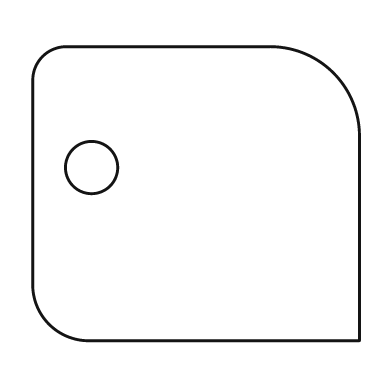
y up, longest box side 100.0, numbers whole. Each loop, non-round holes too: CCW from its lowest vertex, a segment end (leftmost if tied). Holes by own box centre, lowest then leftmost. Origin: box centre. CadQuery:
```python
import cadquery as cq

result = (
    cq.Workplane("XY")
    .moveTo(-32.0, -45.0)
    .lineTo(50.0, -45.0)
    .lineTo(50.0, 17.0)
    .threePointArc((42.0, 37.0), (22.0, 45.0))
    .lineTo(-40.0, 45.0)
    .threePointArc((-47.0, 42.0), (-50.0, 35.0))
    .lineTo(-50.0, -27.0)
    .threePointArc((-45.0, -40.0), (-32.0, -45.0))
    .close()
    .moveTo(-32.0, 8.0)
    .circle(8.0)
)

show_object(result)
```